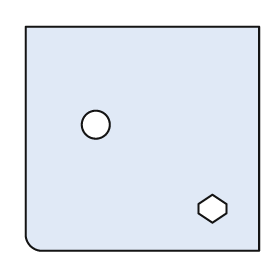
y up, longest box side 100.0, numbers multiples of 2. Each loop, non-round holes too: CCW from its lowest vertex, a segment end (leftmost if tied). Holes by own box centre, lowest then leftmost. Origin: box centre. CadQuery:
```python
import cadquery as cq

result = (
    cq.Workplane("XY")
    .moveTo(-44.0, -48.0)
    .lineTo(50.0, -48.0)
    .lineTo(50.0, 48.0)
    .lineTo(-50.0, 48.0)
    .lineTo(-50.0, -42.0)
    .threePointArc((-48.0, -46.0), (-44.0, -48.0))
    .close()
    .moveTo(30.0, -36.0)
    .lineTo(36.0, -32.0)
    .lineTo(36.0, -28.0)
    .lineTo(30.0, -24.0)
    .lineTo(24.0, -28.0)
    .lineTo(24.0, -32.0)
    .close()
    .moveTo(-20.0, 6.0)
    .circle(6.0)
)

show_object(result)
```